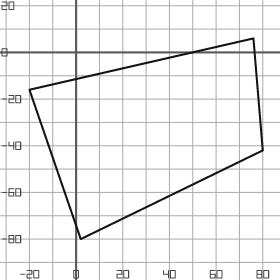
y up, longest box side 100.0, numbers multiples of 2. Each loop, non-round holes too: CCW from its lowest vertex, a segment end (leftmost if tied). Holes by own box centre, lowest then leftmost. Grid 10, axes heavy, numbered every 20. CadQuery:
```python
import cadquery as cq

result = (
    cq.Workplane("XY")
    .moveTo(2.0, -80.0)
    .lineTo(80.0, -42.0)
    .lineTo(76.0, 6.0)
    .lineTo(-20.0, -16.0)
    .close()
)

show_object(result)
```